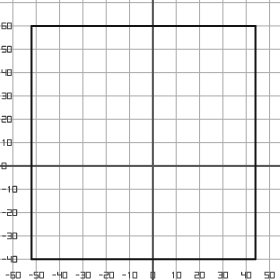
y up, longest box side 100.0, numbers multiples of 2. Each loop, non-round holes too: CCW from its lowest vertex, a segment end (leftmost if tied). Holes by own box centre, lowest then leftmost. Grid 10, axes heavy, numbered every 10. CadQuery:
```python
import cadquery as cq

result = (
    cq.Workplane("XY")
    .moveTo(-52.0, -40.0)
    .lineTo(44.0, -40.0)
    .lineTo(44.0, 60.0)
    .lineTo(-52.0, 60.0)
    .close()
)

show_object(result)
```